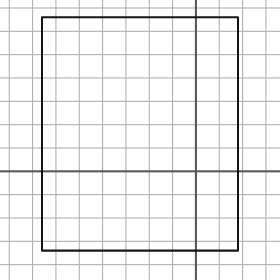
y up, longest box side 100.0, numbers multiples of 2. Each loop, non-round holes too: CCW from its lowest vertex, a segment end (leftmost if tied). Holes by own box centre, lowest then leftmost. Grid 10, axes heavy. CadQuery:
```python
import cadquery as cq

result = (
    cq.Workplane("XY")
    .moveTo(-66.0, -34.0)
    .lineTo(18.0, -34.0)
    .lineTo(18.0, 66.0)
    .lineTo(-66.0, 66.0)
    .close()
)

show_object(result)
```